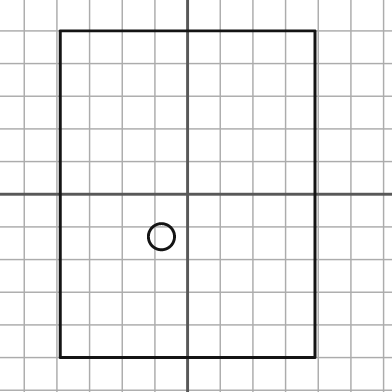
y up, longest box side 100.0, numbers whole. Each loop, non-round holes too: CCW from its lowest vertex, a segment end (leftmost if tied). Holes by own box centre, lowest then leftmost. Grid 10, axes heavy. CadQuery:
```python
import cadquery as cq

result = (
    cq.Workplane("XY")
    .moveTo(-39.0, -50.0)
    .lineTo(39.0, -50.0)
    .lineTo(39.0, 50.0)
    .lineTo(-39.0, 50.0)
    .close()
    .moveTo(-8.0, -13.0)
    .circle(4.0)
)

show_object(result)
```